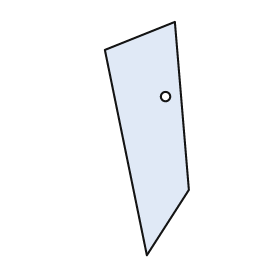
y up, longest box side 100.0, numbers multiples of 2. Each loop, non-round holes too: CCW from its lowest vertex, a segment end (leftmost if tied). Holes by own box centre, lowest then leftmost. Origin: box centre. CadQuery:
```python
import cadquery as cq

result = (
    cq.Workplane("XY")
    .moveTo(0.0, -50.0)
    .lineTo(18.0, -22.0)
    .lineTo(12.0, 50.0)
    .lineTo(-18.0, 38.0)
    .close()
    .moveTo(8.0, 18.0)
    .circle(2.0)
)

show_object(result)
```